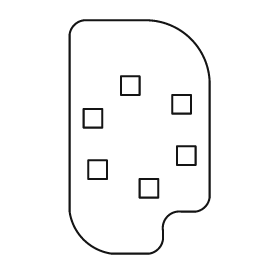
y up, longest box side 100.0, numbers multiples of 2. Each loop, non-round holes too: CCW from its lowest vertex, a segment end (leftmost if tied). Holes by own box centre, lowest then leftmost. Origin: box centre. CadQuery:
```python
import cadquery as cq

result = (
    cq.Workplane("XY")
    .moveTo(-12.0, -50.0)
    .lineTo(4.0, -50.0)
    .threePointArc((8.0, -48.0), (10.0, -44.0))
    .lineTo(10.0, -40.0)
    .threePointArc((12.0, -34.0), (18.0, -32.0))
    .lineTo(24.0, -32.0)
    .threePointArc((28.0, -30.0), (30.0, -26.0))
    .lineTo(30.0, 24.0)
    .threePointArc((22.0, 42.0), (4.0, 50.0))
    .lineTo(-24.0, 50.0)
    .threePointArc((-28.0, 48.0), (-30.0, 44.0))
    .lineTo(-30.0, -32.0)
    .threePointArc((-24.0, -44.0), (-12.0, -50.0))
    .close()
    .moveTo(0.0, -26.0)
    .lineTo(8.0, -26.0)
    .lineTo(8.0, -18.0)
    .lineTo(0.0, -18.0)
    .close()
    .moveTo(-22.0, -18.0)
    .lineTo(-14.0, -18.0)
    .lineTo(-14.0, -10.0)
    .lineTo(-22.0, -10.0)
    .close()
    .moveTo(16.0, -12.0)
    .lineTo(24.0, -12.0)
    .lineTo(24.0, -4.0)
    .lineTo(16.0, -4.0)
    .close()
    .moveTo(-24.0, 4.0)
    .lineTo(-16.0, 4.0)
    .lineTo(-16.0, 12.0)
    .lineTo(-24.0, 12.0)
    .close()
    .moveTo(14.0, 10.0)
    .lineTo(22.0, 10.0)
    .lineTo(22.0, 18.0)
    .lineTo(14.0, 18.0)
    .close()
    .moveTo(-8.0, 18.0)
    .lineTo(0.0, 18.0)
    .lineTo(0.0, 26.0)
    .lineTo(-8.0, 26.0)
    .close()
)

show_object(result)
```